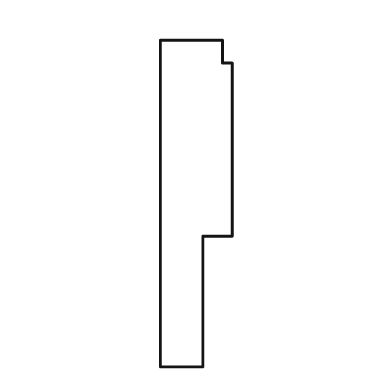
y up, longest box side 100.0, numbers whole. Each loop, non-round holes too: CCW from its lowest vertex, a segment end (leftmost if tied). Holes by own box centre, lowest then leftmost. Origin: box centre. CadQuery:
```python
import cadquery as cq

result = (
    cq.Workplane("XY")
    .moveTo(-11.0, -50.0)
    .lineTo(2.0, -50.0)
    .lineTo(2.0, -10.0)
    .lineTo(11.0, -10.0)
    .lineTo(11.0, 43.0)
    .lineTo(8.0, 43.0)
    .lineTo(8.0, 50.0)
    .lineTo(-11.0, 50.0)
    .close()
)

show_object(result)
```